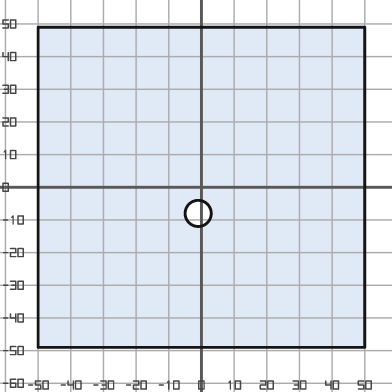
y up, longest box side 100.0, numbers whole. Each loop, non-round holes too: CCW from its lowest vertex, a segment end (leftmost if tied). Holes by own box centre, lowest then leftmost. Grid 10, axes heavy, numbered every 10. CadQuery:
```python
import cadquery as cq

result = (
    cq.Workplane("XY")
    .moveTo(-50.0, -49.0)
    .lineTo(50.0, -49.0)
    .lineTo(50.0, 49.0)
    .lineTo(-50.0, 49.0)
    .close()
    .moveTo(-1.0, -8.0)
    .circle(4.0)
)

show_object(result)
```